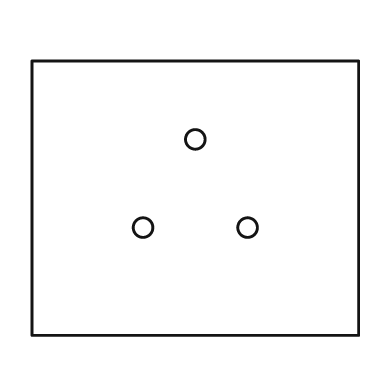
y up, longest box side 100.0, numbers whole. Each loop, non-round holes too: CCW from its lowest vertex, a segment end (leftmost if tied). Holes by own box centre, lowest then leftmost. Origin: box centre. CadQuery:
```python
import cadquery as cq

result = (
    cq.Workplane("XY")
    .moveTo(-50.0, -42.0)
    .lineTo(50.0, -42.0)
    .lineTo(50.0, 42.0)
    .lineTo(-50.0, 42.0)
    .close()
    .moveTo(-16.0, -9.0)
    .circle(3.0)
    .moveTo(16.0, -9.0)
    .circle(3.0)
    .moveTo(0.0, 18.0)
    .circle(3.0)
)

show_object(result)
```